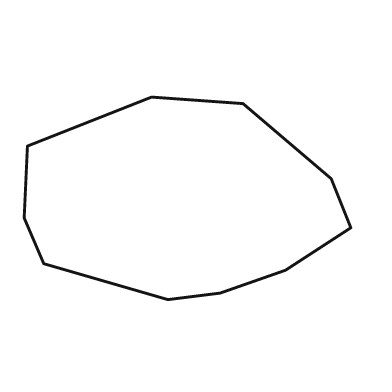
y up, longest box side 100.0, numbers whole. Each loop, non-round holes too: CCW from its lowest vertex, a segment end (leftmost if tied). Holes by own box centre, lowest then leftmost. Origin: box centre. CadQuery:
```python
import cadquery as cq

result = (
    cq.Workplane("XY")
    .moveTo(-6.0, -31.0)
    .lineTo(10.0, -29.0)
    .lineTo(30.0, -22.0)
    .lineTo(50.0, -9.0)
    .lineTo(44.0, 6.0)
    .lineTo(17.0, 29.0)
    .lineTo(-11.0, 31.0)
    .lineTo(-49.0, 16.0)
    .lineTo(-50.0, -6.0)
    .lineTo(-44.0, -20.0)
    .close()
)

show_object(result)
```